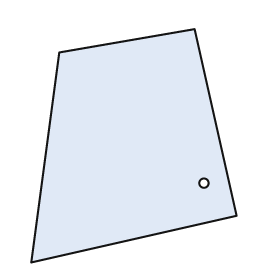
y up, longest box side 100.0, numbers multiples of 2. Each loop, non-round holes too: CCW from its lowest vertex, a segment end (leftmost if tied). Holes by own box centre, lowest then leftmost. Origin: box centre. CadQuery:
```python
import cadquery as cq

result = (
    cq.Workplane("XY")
    .moveTo(-44.0, -50.0)
    .lineTo(44.0, -30.0)
    .lineTo(26.0, 50.0)
    .lineTo(-32.0, 40.0)
    .close()
    .moveTo(30.0, -16.0)
    .circle(2.0)
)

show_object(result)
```